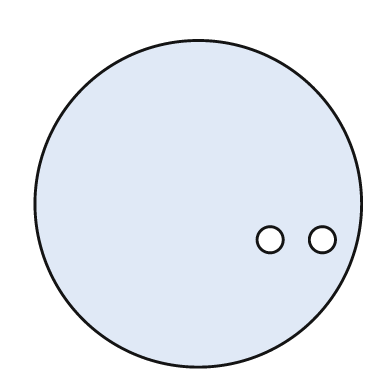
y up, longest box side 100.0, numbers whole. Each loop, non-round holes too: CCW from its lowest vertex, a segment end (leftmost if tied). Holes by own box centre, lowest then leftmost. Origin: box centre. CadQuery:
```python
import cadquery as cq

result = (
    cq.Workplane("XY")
    .moveTo(0.0, 0.0)
    .circle(50.0)
    .moveTo(22.0, -11.0)
    .circle(4.0)
    .moveTo(38.0, -11.0)
    .circle(4.0)
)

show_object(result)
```